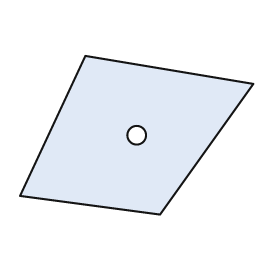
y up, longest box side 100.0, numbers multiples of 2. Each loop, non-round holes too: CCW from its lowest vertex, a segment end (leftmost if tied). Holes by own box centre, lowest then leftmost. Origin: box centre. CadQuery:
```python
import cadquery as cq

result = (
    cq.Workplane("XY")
    .moveTo(10.0, -34.0)
    .lineTo(50.0, 22.0)
    .lineTo(-22.0, 34.0)
    .lineTo(-50.0, -26.0)
    .close()
    .moveTo(0.0, 0.0)
    .circle(4.0)
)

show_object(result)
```